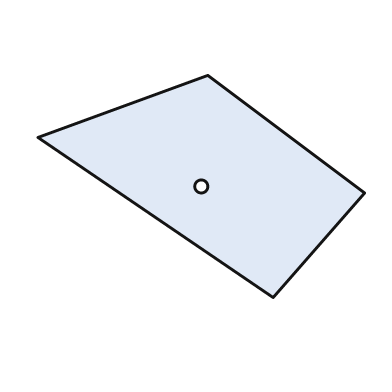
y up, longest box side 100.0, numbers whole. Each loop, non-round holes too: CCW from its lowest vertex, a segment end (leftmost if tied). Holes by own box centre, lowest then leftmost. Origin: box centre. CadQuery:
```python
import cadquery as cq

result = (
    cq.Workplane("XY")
    .moveTo(22.0, -34.0)
    .lineTo(50.0, -2.0)
    .lineTo(2.0, 34.0)
    .lineTo(-50.0, 15.0)
    .close()
    .moveTo(0.0, 0.0)
    .circle(2.0)
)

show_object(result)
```